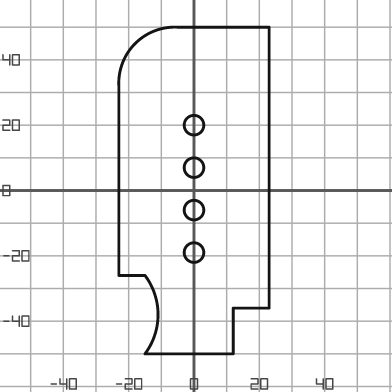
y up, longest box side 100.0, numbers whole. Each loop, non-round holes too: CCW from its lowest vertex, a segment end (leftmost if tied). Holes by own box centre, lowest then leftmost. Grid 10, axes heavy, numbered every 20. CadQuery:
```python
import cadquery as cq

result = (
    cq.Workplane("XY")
    .moveTo(-15.0, -50.0)
    .lineTo(12.0, -50.0)
    .lineTo(12.0, -36.0)
    .lineTo(23.0, -36.0)
    .lineTo(23.0, 50.0)
    .lineTo(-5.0, 50.0)
    .threePointArc((-18.0, 45.0), (-23.0, 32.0))
    .lineTo(-23.0, -26.0)
    .lineTo(-15.0, -26.0)
    .threePointArc((-11.0, -38.0), (-15.0, -50.0))
    .close()
    .moveTo(0.0, -19.0)
    .circle(3.0)
    .moveTo(0.0, -6.0)
    .circle(3.0)
    .moveTo(0.0, 7.0)
    .circle(3.0)
    .moveTo(0.0, 20.0)
    .circle(3.0)
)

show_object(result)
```